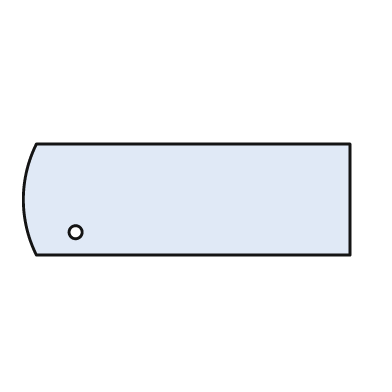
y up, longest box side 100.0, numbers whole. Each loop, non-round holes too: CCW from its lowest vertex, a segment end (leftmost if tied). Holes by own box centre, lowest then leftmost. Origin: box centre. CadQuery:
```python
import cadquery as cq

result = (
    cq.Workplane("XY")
    .moveTo(-46.0, -17.0)
    .lineTo(50.0, -17.0)
    .lineTo(50.0, 17.0)
    .lineTo(-46.0, 17.0)
    .threePointArc((-50.0, 0.0), (-46.0, -17.0))
    .close()
    .moveTo(-34.0, -10.0)
    .circle(2.0)
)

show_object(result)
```